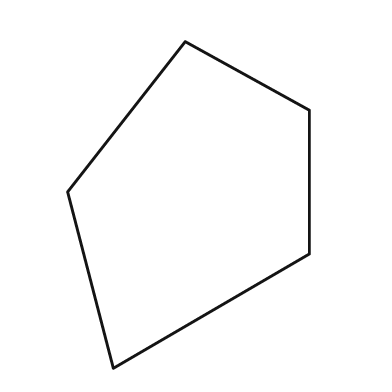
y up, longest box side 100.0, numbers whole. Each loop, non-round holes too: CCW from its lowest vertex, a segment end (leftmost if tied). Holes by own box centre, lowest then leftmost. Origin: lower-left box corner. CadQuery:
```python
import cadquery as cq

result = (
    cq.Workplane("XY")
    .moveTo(14.0, 0.0)
    .lineTo(74.0, 35.0)
    .lineTo(74.0, 79.0)
    .lineTo(36.0, 100.0)
    .lineTo(0.0, 54.0)
    .close()
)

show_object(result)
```